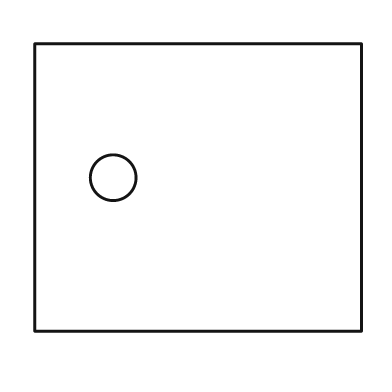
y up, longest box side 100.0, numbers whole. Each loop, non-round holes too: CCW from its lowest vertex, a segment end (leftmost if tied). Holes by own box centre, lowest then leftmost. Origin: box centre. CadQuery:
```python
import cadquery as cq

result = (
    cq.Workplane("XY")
    .moveTo(-50.0, -44.0)
    .lineTo(50.0, -44.0)
    .lineTo(50.0, 44.0)
    .lineTo(-50.0, 44.0)
    .close()
    .moveTo(-26.0, 3.0)
    .circle(7.0)
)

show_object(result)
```